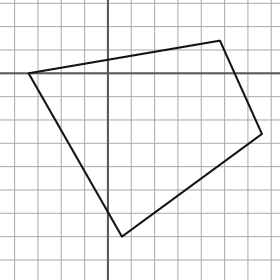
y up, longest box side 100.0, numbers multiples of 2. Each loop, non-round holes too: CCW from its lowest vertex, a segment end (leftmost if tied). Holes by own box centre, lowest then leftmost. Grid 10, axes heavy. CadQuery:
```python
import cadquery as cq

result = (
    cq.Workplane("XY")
    .moveTo(6.0, -70.0)
    .lineTo(66.0, -26.0)
    .lineTo(48.0, 14.0)
    .lineTo(-34.0, 0.0)
    .close()
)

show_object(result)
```